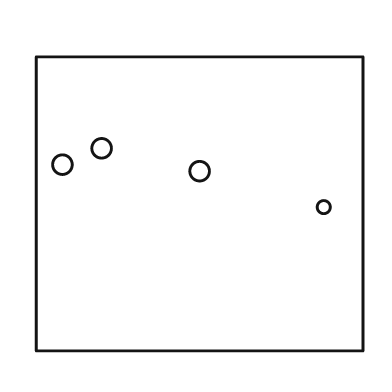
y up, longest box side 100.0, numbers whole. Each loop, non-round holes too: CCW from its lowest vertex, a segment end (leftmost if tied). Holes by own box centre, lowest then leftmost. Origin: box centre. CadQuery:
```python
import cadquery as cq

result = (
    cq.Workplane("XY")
    .moveTo(-50.0, -45.0)
    .lineTo(50.0, -45.0)
    .lineTo(50.0, 45.0)
    .lineTo(-50.0, 45.0)
    .close()
    .moveTo(38.0, -1.0)
    .circle(2.0)
    .moveTo(0.0, 10.0)
    .circle(3.0)
    .moveTo(-42.0, 12.0)
    .circle(3.0)
    .moveTo(-30.0, 17.0)
    .circle(3.0)
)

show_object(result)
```